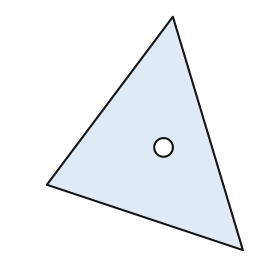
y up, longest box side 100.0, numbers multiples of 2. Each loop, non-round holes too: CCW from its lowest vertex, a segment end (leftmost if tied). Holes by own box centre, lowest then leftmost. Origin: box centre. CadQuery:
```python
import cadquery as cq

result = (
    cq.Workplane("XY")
    .moveTo(42.0, -50.0)
    .lineTo(12.0, 50.0)
    .lineTo(-42.0, -22.0)
    .close()
    .moveTo(8.0, -6.0)
    .circle(4.0)
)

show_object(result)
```